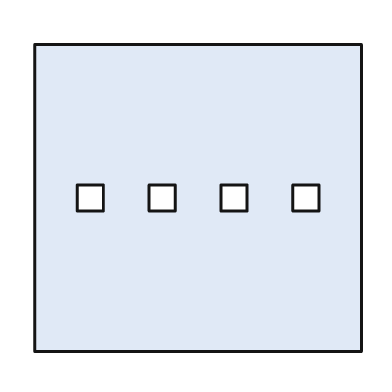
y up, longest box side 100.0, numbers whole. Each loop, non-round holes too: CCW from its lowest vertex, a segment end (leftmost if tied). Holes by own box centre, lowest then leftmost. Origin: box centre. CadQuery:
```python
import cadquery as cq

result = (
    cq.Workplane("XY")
    .moveTo(-50.0, -47.0)
    .lineTo(50.0, -47.0)
    .lineTo(50.0, 47.0)
    .lineTo(-50.0, 47.0)
    .close()
    .moveTo(-37.0, -4.0)
    .lineTo(-29.0, -4.0)
    .lineTo(-29.0, 4.0)
    .lineTo(-37.0, 4.0)
    .close()
    .moveTo(-15.0, -4.0)
    .lineTo(-7.0, -4.0)
    .lineTo(-7.0, 4.0)
    .lineTo(-15.0, 4.0)
    .close()
    .moveTo(7.0, -4.0)
    .lineTo(15.0, -4.0)
    .lineTo(15.0, 4.0)
    .lineTo(7.0, 4.0)
    .close()
    .moveTo(29.0, -4.0)
    .lineTo(37.0, -4.0)
    .lineTo(37.0, 4.0)
    .lineTo(29.0, 4.0)
    .close()
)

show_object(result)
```